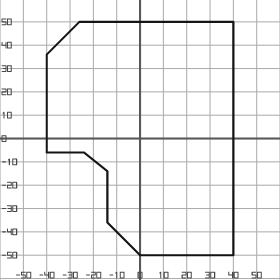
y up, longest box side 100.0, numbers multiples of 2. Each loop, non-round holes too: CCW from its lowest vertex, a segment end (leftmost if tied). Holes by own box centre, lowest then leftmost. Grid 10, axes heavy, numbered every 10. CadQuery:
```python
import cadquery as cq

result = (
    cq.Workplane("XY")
    .moveTo(0.0, -50.0)
    .lineTo(40.0, -50.0)
    .lineTo(40.0, 50.0)
    .lineTo(-26.0, 50.0)
    .lineTo(-40.0, 36.0)
    .lineTo(-40.0, -6.0)
    .lineTo(-24.0, -6.0)
    .lineTo(-14.0, -14.0)
    .lineTo(-14.0, -36.0)
    .close()
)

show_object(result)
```